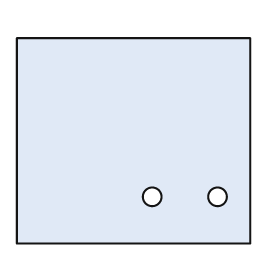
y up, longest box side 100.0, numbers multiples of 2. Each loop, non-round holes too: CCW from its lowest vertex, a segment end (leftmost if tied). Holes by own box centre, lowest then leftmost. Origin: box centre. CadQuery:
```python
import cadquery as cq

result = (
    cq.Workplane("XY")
    .moveTo(-50.0, -44.0)
    .lineTo(50.0, -44.0)
    .lineTo(50.0, 44.0)
    .lineTo(-50.0, 44.0)
    .close()
    .moveTo(8.0, -24.0)
    .circle(4.0)
    .moveTo(36.0, -24.0)
    .circle(4.0)
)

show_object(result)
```